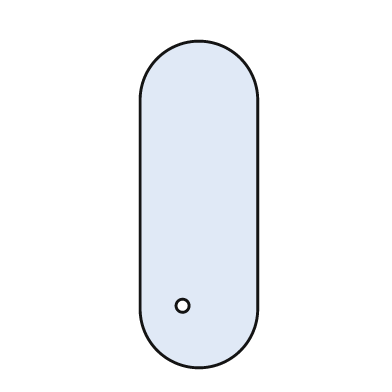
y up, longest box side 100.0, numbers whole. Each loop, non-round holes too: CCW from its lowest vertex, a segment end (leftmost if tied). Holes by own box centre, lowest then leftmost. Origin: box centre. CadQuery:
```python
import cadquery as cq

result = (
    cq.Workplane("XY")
    .moveTo(-18.0, -32.0)
    .threePointArc((0.0, -50.0), (18.0, -32.0))
    .lineTo(18.0, 32.0)
    .threePointArc((0.0, 50.0), (-18.0, 32.0))
    .close()
    .moveTo(-5.0, -31.0)
    .circle(2.0)
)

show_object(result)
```